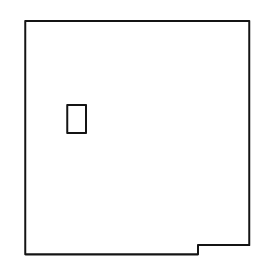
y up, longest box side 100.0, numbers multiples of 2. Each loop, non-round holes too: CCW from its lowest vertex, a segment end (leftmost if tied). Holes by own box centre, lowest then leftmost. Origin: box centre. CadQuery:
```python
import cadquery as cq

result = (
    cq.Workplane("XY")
    .moveTo(-48.0, -50.0)
    .lineTo(26.0, -50.0)
    .lineTo(26.0, -46.0)
    .lineTo(48.0, -46.0)
    .lineTo(48.0, 50.0)
    .lineTo(-48.0, 50.0)
    .close()
    .moveTo(-30.0, 2.0)
    .lineTo(-22.0, 2.0)
    .lineTo(-22.0, 14.0)
    .lineTo(-30.0, 14.0)
    .close()
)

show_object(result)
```